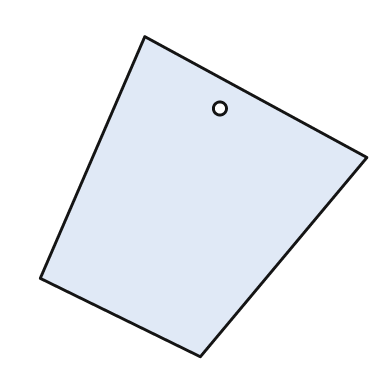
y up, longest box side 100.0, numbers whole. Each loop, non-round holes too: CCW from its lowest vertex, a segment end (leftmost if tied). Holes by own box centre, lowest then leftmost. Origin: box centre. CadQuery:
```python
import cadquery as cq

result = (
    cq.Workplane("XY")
    .moveTo(-1.0, -49.0)
    .lineTo(50.0, 12.0)
    .lineTo(-18.0, 49.0)
    .lineTo(-50.0, -25.0)
    .close()
    .moveTo(5.0, 27.0)
    .circle(2.0)
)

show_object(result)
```